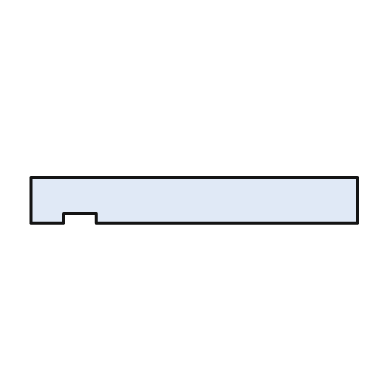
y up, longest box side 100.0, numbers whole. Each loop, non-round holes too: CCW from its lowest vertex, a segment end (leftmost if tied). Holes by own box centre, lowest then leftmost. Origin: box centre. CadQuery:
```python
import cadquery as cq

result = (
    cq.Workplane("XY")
    .moveTo(-50.0, -7.0)
    .lineTo(-40.0, -7.0)
    .lineTo(-40.0, -4.0)
    .lineTo(-30.0, -4.0)
    .lineTo(-30.0, -7.0)
    .lineTo(50.0, -7.0)
    .lineTo(50.0, 7.0)
    .lineTo(-50.0, 7.0)
    .close()
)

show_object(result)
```